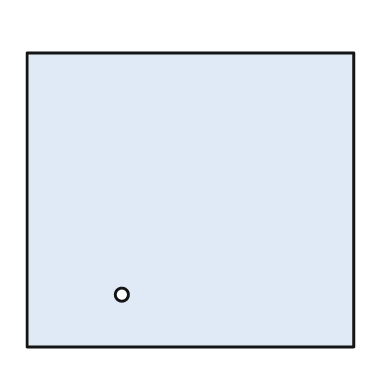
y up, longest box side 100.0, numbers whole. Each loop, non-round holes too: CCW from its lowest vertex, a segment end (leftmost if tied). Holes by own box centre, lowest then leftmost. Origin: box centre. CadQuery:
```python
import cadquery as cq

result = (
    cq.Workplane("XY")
    .moveTo(-50.0, -45.0)
    .lineTo(50.0, -45.0)
    .lineTo(50.0, 45.0)
    .lineTo(-50.0, 45.0)
    .close()
    .moveTo(-21.0, -29.0)
    .circle(2.0)
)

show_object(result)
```